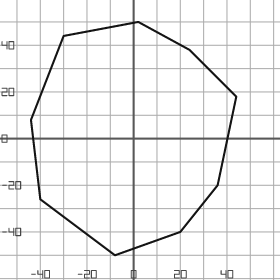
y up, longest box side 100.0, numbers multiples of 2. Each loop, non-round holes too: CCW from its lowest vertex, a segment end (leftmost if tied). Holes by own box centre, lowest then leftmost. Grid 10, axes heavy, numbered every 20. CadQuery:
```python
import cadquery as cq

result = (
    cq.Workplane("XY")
    .moveTo(-8.0, -50.0)
    .lineTo(20.0, -40.0)
    .lineTo(36.0, -20.0)
    .lineTo(44.0, 18.0)
    .lineTo(24.0, 38.0)
    .lineTo(2.0, 50.0)
    .lineTo(-30.0, 44.0)
    .lineTo(-44.0, 8.0)
    .lineTo(-40.0, -26.0)
    .close()
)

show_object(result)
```